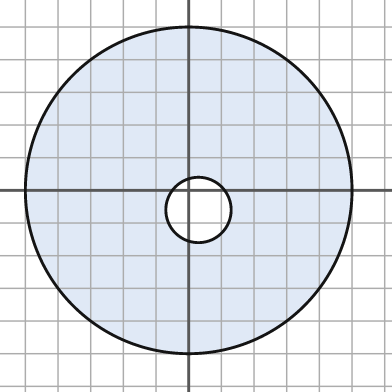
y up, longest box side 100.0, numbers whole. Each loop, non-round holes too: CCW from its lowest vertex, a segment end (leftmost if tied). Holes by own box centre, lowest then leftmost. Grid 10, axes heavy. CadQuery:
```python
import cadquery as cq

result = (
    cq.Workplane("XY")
    .moveTo(0.0, 0.0)
    .circle(50.0)
    .moveTo(3.0, -6.0)
    .circle(10.0)
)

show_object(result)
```